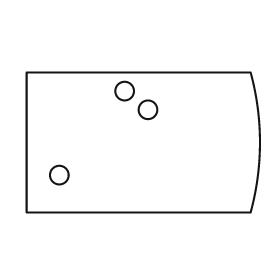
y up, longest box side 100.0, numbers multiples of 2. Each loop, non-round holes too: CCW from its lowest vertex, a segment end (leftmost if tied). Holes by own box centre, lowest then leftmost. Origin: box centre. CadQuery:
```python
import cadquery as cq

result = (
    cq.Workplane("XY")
    .moveTo(-50.0, -30.0)
    .lineTo(46.0, -30.0)
    .threePointArc((50.0, 0.0), (46.0, 30.0))
    .lineTo(-50.0, 30.0)
    .close()
    .moveTo(-36.0, -14.0)
    .circle(4.0)
    .moveTo(2.0, 14.0)
    .circle(4.0)
    .moveTo(-8.0, 22.0)
    .circle(4.0)
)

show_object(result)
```